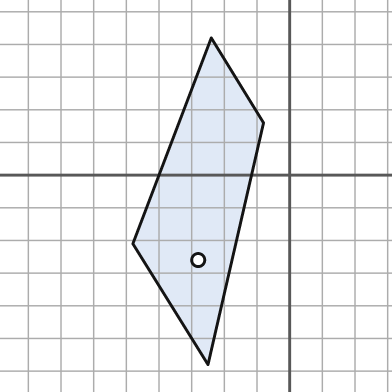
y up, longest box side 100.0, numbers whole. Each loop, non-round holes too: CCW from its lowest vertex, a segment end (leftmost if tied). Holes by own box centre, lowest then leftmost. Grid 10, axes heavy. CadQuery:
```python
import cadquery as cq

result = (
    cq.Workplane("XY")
    .moveTo(-25.0, -58.0)
    .lineTo(-8.0, 16.0)
    .lineTo(-24.0, 42.0)
    .lineTo(-48.0, -21.0)
    .close()
    .moveTo(-28.0, -26.0)
    .circle(2.0)
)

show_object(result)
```